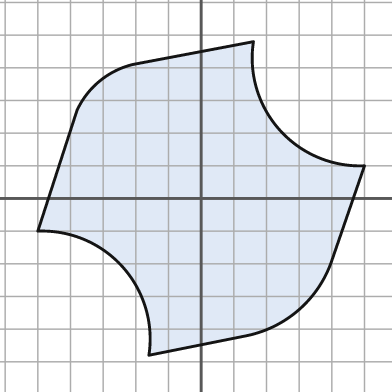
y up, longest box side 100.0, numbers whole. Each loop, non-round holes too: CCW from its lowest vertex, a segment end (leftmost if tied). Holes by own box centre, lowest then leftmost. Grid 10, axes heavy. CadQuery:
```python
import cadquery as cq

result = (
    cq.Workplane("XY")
    .moveTo(-16.0, -48.0)
    .lineTo(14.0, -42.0)
    .threePointArc((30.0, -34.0), (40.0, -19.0))
    .lineTo(50.0, 10.0)
    .threePointArc((24.0, 21.0), (16.0, 48.0))
    .lineTo(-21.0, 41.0)
    .threePointArc((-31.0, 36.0), (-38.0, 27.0))
    .lineTo(-50.0, -10.0)
    .threePointArc((-24.0, -21.0), (-16.0, -48.0))
    .close()
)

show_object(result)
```